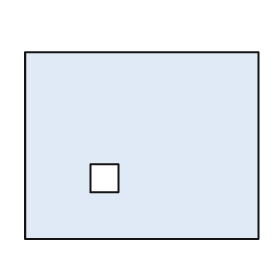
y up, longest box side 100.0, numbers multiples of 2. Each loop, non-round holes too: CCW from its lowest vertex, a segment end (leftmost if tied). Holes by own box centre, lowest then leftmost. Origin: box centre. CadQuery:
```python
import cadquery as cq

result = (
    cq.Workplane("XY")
    .moveTo(-50.0, -40.0)
    .lineTo(50.0, -40.0)
    .lineTo(50.0, 40.0)
    .lineTo(-50.0, 40.0)
    .close()
    .moveTo(-22.0, -20.0)
    .lineTo(-10.0, -20.0)
    .lineTo(-10.0, -8.0)
    .lineTo(-22.0, -8.0)
    .close()
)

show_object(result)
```